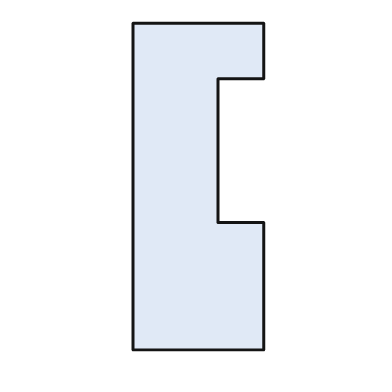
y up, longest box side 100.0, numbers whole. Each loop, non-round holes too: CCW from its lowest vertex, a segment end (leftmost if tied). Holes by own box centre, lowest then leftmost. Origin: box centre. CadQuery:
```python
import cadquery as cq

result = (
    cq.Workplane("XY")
    .moveTo(-20.0, -50.0)
    .lineTo(20.0, -50.0)
    .lineTo(20.0, -11.0)
    .lineTo(6.0, -11.0)
    .lineTo(6.0, 33.0)
    .lineTo(20.0, 33.0)
    .lineTo(20.0, 50.0)
    .lineTo(-20.0, 50.0)
    .close()
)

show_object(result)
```